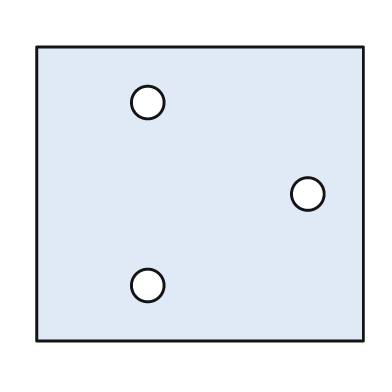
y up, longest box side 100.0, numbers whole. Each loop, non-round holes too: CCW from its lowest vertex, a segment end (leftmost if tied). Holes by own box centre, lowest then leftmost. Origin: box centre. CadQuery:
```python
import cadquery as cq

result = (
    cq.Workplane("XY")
    .moveTo(-50.0, -45.0)
    .lineTo(50.0, -45.0)
    .lineTo(50.0, 45.0)
    .lineTo(-50.0, 45.0)
    .close()
    .moveTo(-16.0, -28.0)
    .circle(5.0)
    .moveTo(33.0, 0.0)
    .circle(5.0)
    .moveTo(-16.0, 28.0)
    .circle(5.0)
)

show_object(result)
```